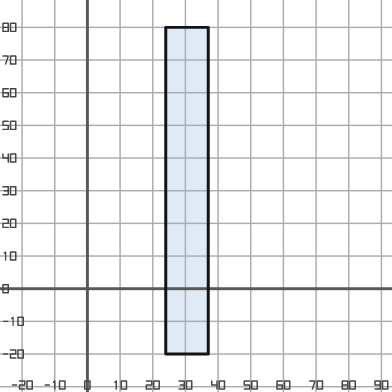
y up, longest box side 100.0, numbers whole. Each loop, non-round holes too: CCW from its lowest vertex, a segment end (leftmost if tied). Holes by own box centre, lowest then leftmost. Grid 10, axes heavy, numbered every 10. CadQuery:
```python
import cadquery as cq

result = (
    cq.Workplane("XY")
    .moveTo(24.0, -20.0)
    .lineTo(37.0, -20.0)
    .lineTo(37.0, 80.0)
    .lineTo(24.0, 80.0)
    .close()
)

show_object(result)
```